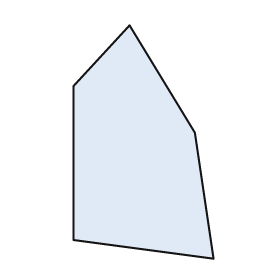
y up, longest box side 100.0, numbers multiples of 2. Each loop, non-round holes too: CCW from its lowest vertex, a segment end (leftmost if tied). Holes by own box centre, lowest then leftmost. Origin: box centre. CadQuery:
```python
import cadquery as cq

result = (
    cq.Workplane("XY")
    .moveTo(30.0, -50.0)
    .lineTo(22.0, 4.0)
    .lineTo(-6.0, 50.0)
    .lineTo(-30.0, 24.0)
    .lineTo(-30.0, -42.0)
    .close()
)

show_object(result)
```